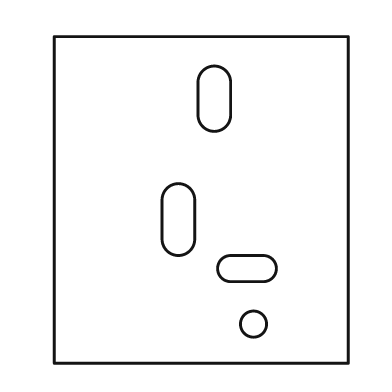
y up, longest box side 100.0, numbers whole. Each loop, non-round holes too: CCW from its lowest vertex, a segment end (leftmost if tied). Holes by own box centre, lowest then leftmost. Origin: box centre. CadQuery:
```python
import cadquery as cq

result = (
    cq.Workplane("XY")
    .moveTo(-45.0, -50.0)
    .lineTo(45.0, -50.0)
    .lineTo(45.0, 50.0)
    .lineTo(-45.0, 50.0)
    .close()
    .moveTo(16.0, -38.0)
    .circle(4.0)
    .moveTo(9.0, -25.0)
    .lineTo(19.0, -25.0)
    .threePointArc((23.0, -21.0), (19.0, -17.0))
    .lineTo(9.0, -17.0)
    .threePointArc((5.0, -21.0), (9.0, -25.0))
    .close()
    .moveTo(-12.0, -12.0)
    .threePointArc((-7.0, -17.0), (-2.0, -12.0))
    .lineTo(-2.0, 0.0)
    .threePointArc((-7.0, 5.0), (-12.0, 0.0))
    .close()
    .moveTo(-1.0, 26.0)
    .threePointArc((4.0, 21.0), (9.0, 26.0))
    .lineTo(9.0, 36.0)
    .threePointArc((4.0, 41.0), (-1.0, 36.0))
    .close()
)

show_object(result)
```